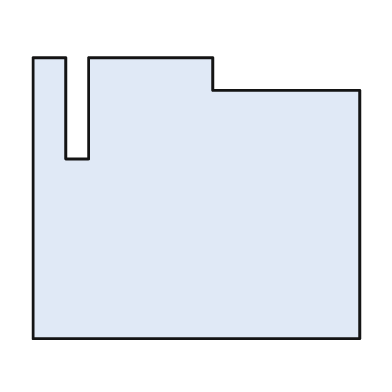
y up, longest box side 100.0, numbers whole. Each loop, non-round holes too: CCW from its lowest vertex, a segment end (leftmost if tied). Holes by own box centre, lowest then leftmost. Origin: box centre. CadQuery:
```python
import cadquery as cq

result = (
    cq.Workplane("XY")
    .moveTo(-50.0, -43.0)
    .lineTo(50.0, -43.0)
    .lineTo(50.0, 33.0)
    .lineTo(5.0, 33.0)
    .lineTo(5.0, 43.0)
    .lineTo(-33.0, 43.0)
    .lineTo(-33.0, 12.0)
    .lineTo(-40.0, 12.0)
    .lineTo(-40.0, 43.0)
    .lineTo(-50.0, 43.0)
    .close()
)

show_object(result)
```